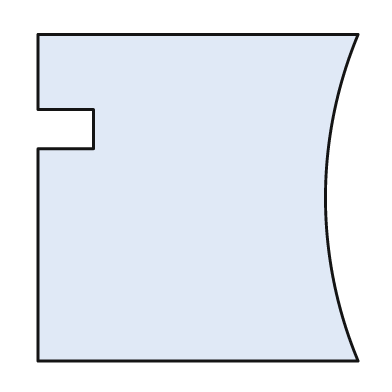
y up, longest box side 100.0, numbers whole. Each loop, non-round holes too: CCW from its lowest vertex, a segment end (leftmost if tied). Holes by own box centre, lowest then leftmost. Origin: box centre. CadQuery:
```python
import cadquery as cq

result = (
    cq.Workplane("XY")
    .moveTo(-49.0, -50.0)
    .lineTo(49.0, -50.0)
    .threePointArc((39.0, 0.0), (49.0, 50.0))
    .lineTo(-49.0, 50.0)
    .lineTo(-49.0, 27.0)
    .lineTo(-32.0, 27.0)
    .lineTo(-32.0, 15.0)
    .lineTo(-49.0, 15.0)
    .close()
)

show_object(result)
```